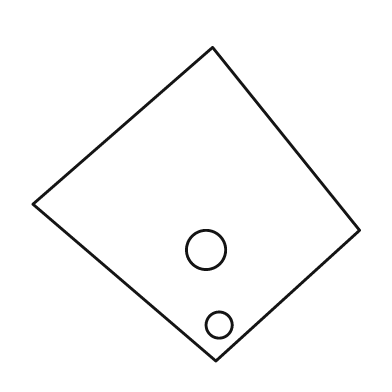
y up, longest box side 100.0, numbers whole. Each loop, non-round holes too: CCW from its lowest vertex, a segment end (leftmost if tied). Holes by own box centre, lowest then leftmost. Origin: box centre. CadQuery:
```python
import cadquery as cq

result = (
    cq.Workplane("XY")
    .moveTo(6.0, -48.0)
    .lineTo(50.0, -8.0)
    .lineTo(5.0, 48.0)
    .lineTo(-50.0, 0.0)
    .close()
    .moveTo(7.0, -37.0)
    .circle(4.0)
    .moveTo(3.0, -14.0)
    .circle(6.0)
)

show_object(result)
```